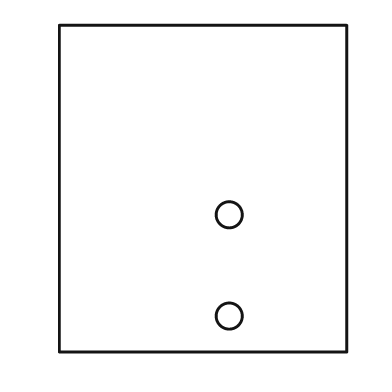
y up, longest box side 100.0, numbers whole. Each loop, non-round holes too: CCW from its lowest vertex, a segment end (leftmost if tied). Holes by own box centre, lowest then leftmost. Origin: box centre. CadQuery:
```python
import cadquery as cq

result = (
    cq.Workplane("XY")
    .moveTo(-44.0, -50.0)
    .lineTo(44.0, -50.0)
    .lineTo(44.0, 50.0)
    .lineTo(-44.0, 50.0)
    .close()
    .moveTo(8.0, -39.0)
    .circle(4.0)
    .moveTo(8.0, -8.0)
    .circle(4.0)
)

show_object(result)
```